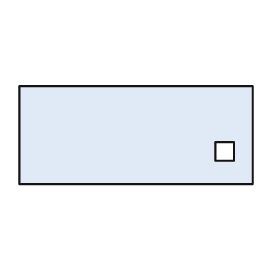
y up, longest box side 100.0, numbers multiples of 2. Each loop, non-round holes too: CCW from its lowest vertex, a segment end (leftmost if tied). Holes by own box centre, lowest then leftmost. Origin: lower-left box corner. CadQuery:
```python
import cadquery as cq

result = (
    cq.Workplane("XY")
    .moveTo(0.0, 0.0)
    .lineTo(100.0, 0.0)
    .lineTo(100.0, 42.0)
    .lineTo(0.0, 42.0)
    .close()
    .moveTo(84.0, 10.0)
    .lineTo(92.0, 10.0)
    .lineTo(92.0, 18.0)
    .lineTo(84.0, 18.0)
    .close()
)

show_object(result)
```